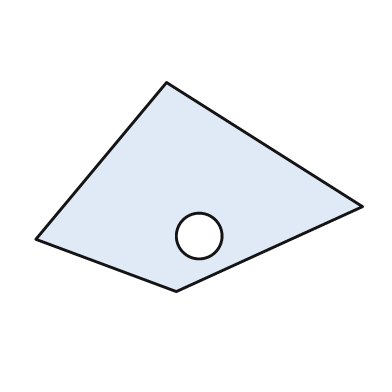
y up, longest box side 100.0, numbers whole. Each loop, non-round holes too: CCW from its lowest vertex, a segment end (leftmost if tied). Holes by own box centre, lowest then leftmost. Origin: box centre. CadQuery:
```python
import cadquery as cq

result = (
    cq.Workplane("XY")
    .moveTo(-7.0, -32.0)
    .lineTo(50.0, -6.0)
    .lineTo(-10.0, 32.0)
    .lineTo(-50.0, -16.0)
    .close()
    .moveTo(0.0, -15.0)
    .circle(7.0)
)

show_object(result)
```